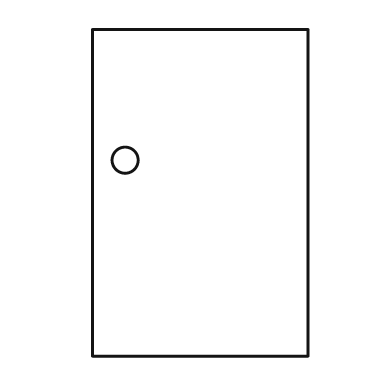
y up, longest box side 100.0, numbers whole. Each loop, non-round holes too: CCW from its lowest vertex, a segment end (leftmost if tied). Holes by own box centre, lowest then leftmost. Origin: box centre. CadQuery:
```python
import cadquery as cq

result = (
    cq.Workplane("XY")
    .moveTo(-33.0, -50.0)
    .lineTo(33.0, -50.0)
    .lineTo(33.0, 50.0)
    .lineTo(-33.0, 50.0)
    .close()
    .moveTo(-23.0, 10.0)
    .circle(4.0)
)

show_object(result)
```